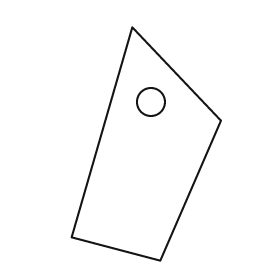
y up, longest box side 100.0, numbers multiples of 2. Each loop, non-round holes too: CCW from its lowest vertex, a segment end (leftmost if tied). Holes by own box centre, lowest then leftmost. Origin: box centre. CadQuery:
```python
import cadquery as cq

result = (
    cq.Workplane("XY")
    .moveTo(6.0, -50.0)
    .lineTo(32.0, 10.0)
    .lineTo(-6.0, 50.0)
    .lineTo(-32.0, -40.0)
    .close()
    .moveTo(2.0, 18.0)
    .circle(6.0)
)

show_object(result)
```